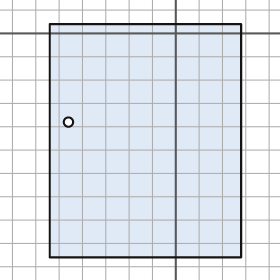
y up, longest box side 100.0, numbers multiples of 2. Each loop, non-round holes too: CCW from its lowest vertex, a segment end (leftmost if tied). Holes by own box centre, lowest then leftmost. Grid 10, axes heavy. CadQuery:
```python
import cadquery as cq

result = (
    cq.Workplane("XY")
    .moveTo(-54.0, -96.0)
    .lineTo(28.0, -96.0)
    .lineTo(28.0, 4.0)
    .lineTo(-54.0, 4.0)
    .close()
    .moveTo(-46.0, -38.0)
    .circle(2.0)
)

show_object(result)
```